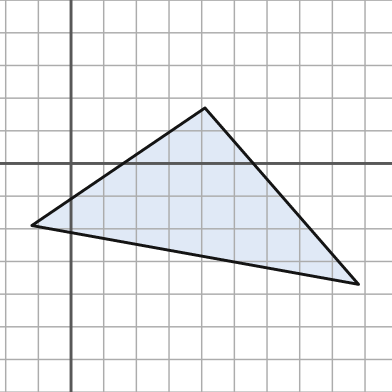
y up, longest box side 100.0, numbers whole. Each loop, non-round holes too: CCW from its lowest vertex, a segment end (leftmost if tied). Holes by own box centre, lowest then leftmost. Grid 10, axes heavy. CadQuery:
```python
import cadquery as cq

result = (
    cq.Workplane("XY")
    .moveTo(88.0, -37.0)
    .lineTo(41.0, 17.0)
    .lineTo(-12.0, -19.0)
    .close()
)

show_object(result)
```